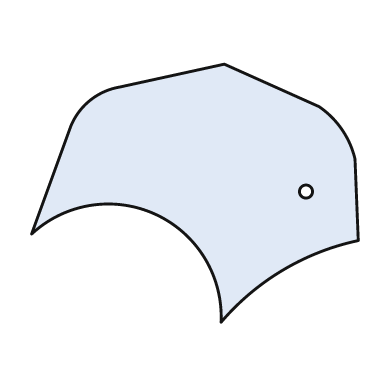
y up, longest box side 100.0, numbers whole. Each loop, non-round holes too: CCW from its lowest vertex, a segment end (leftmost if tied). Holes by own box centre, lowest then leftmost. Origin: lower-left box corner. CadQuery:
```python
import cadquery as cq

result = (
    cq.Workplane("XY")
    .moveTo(58.0, 0.0)
    .threePointArc((77.0, 16.0), (100.0, 25.0))
    .lineTo(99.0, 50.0)
    .threePointArc((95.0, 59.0), (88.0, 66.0))
    .lineTo(59.0, 79.0)
    .lineTo(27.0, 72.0)
    .threePointArc((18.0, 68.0), (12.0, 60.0))
    .lineTo(0.0, 27.0)
    .threePointArc((38.0, 33.0), (58.0, 0.0))
    .close()
    .moveTo(84.0, 40.0)
    .circle(2.0)
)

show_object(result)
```